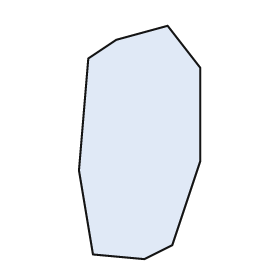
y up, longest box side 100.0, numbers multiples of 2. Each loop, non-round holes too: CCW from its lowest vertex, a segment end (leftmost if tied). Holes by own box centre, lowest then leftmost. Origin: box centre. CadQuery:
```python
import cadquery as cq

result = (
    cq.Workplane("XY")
    .moveTo(2.0, -50.0)
    .lineTo(14.0, -44.0)
    .lineTo(26.0, -8.0)
    .lineTo(26.0, 32.0)
    .lineTo(12.0, 50.0)
    .lineTo(-10.0, 44.0)
    .lineTo(-22.0, 36.0)
    .lineTo(-26.0, -12.0)
    .lineTo(-20.0, -48.0)
    .close()
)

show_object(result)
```